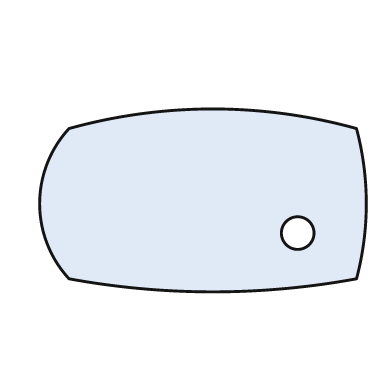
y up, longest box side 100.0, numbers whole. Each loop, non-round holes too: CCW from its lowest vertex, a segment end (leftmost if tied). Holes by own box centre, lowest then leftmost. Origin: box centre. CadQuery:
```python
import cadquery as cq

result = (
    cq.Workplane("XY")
    .moveTo(-41.0, -24.0)
    .threePointArc((3.0, -28.0), (47.0, -24.0))
    .threePointArc((50.0, -1.0), (47.0, 22.0))
    .threePointArc((3.0, 28.0), (-41.0, 22.0))
    .threePointArc((-50.0, -1.0), (-41.0, -24.0))
    .close()
    .moveTo(29.0, -10.0)
    .circle(5.0)
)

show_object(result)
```